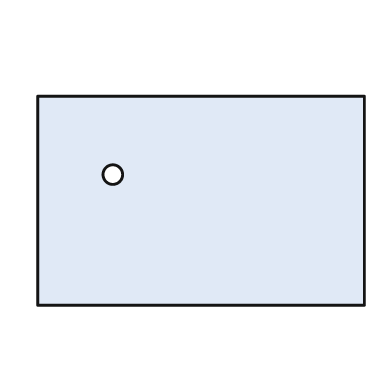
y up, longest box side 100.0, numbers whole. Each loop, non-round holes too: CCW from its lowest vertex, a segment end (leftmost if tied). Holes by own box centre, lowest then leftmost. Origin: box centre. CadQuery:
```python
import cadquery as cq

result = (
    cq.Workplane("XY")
    .moveTo(-50.0, -32.0)
    .lineTo(50.0, -32.0)
    .lineTo(50.0, 32.0)
    .lineTo(-50.0, 32.0)
    .close()
    .moveTo(-27.0, 8.0)
    .circle(3.0)
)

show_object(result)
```